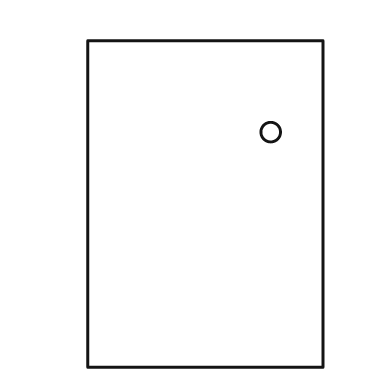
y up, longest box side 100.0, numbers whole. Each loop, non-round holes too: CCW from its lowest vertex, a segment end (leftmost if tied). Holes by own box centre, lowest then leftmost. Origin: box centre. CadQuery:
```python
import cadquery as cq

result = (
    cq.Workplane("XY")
    .moveTo(-36.0, -50.0)
    .lineTo(36.0, -50.0)
    .lineTo(36.0, 50.0)
    .lineTo(-36.0, 50.0)
    .close()
    .moveTo(20.0, 22.0)
    .circle(3.0)
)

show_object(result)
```